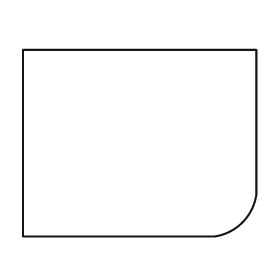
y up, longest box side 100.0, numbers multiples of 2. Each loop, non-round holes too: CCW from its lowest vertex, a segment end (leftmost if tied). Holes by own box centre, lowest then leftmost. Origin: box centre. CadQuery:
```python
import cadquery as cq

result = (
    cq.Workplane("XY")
    .moveTo(-50.0, -40.0)
    .lineTo(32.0, -40.0)
    .threePointArc((44.0, -34.0), (50.0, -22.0))
    .lineTo(50.0, 40.0)
    .lineTo(-50.0, 40.0)
    .close()
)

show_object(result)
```